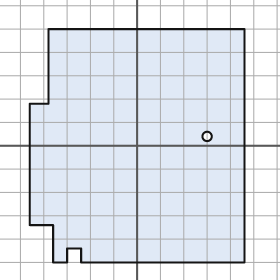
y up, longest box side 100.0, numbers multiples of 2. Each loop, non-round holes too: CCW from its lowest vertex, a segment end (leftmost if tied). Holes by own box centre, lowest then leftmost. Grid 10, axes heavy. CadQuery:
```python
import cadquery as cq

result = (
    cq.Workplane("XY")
    .moveTo(-36.0, -50.0)
    .lineTo(-30.0, -50.0)
    .lineTo(-30.0, -44.0)
    .lineTo(-24.0, -44.0)
    .lineTo(-24.0, -50.0)
    .lineTo(46.0, -50.0)
    .lineTo(46.0, 50.0)
    .lineTo(-38.0, 50.0)
    .lineTo(-38.0, 18.0)
    .lineTo(-46.0, 18.0)
    .lineTo(-46.0, -34.0)
    .lineTo(-36.0, -34.0)
    .close()
    .moveTo(30.0, 4.0)
    .circle(2.0)
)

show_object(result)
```